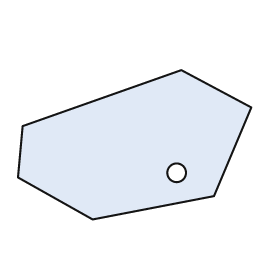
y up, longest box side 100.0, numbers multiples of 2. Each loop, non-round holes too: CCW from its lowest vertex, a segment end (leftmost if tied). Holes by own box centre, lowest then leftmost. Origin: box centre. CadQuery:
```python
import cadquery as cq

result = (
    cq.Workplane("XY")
    .moveTo(-18.0, -32.0)
    .lineTo(34.0, -22.0)
    .lineTo(50.0, 16.0)
    .lineTo(20.0, 32.0)
    .lineTo(-48.0, 8.0)
    .lineTo(-50.0, -14.0)
    .close()
    .moveTo(18.0, -12.0)
    .circle(4.0)
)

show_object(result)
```